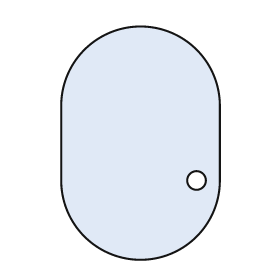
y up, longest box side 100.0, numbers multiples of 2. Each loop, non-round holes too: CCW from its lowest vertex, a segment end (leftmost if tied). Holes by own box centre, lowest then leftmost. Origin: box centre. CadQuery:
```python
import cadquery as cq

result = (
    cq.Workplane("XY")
    .moveTo(-34.0, -16.0)
    .threePointArc((0.0, -50.0), (34.0, -16.0))
    .lineTo(34.0, 16.0)
    .threePointArc((0.0, 50.0), (-34.0, 16.0))
    .close()
    .moveTo(24.0, -16.0)
    .circle(4.0)
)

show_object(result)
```